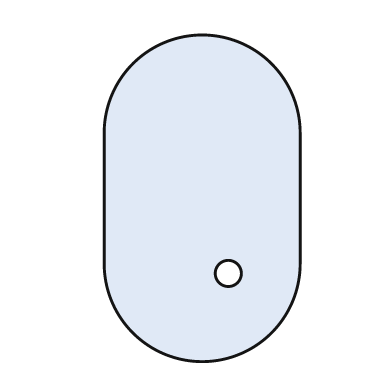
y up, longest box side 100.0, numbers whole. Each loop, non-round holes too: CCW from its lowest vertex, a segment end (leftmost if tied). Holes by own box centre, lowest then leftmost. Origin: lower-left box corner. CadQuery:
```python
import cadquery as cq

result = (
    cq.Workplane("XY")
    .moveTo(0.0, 30.0)
    .threePointArc((30.0, 0.0), (60.0, 30.0))
    .lineTo(60.0, 70.0)
    .threePointArc((30.0, 100.0), (0.0, 70.0))
    .close()
    .moveTo(38.0, 27.0)
    .circle(4.0)
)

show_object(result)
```